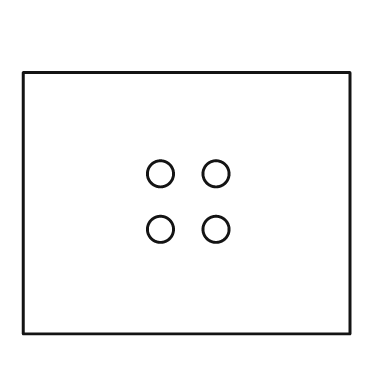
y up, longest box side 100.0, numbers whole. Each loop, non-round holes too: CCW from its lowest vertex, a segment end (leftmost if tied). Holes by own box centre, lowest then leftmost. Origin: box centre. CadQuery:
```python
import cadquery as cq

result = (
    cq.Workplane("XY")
    .moveTo(-50.0, -40.0)
    .lineTo(50.0, -40.0)
    .lineTo(50.0, 40.0)
    .lineTo(-50.0, 40.0)
    .close()
    .moveTo(-8.0, -8.0)
    .circle(4.0)
    .moveTo(9.0, -8.0)
    .circle(4.0)
    .moveTo(-8.0, 9.0)
    .circle(4.0)
    .moveTo(9.0, 9.0)
    .circle(4.0)
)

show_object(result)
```